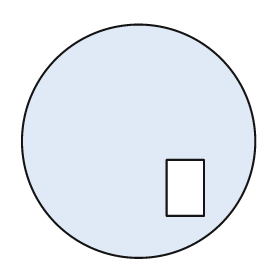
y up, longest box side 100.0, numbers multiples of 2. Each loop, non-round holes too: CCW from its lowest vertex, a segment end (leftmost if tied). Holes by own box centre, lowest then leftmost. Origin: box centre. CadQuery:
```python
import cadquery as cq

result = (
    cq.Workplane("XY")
    .moveTo(0.0, 0.0)
    .circle(50.0)
    .moveTo(12.0, -32.0)
    .lineTo(28.0, -32.0)
    .lineTo(28.0, -8.0)
    .lineTo(12.0, -8.0)
    .close()
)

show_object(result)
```